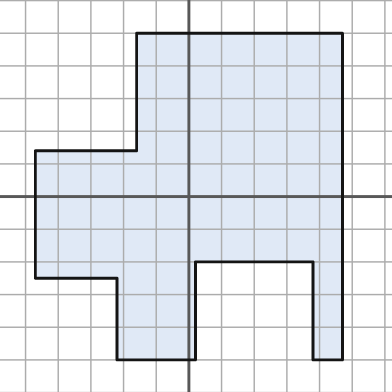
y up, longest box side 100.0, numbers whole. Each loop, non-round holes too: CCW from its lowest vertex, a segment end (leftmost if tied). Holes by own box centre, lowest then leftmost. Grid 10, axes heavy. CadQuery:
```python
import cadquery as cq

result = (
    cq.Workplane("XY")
    .moveTo(-22.0, -50.0)
    .lineTo(2.0, -50.0)
    .lineTo(2.0, -20.0)
    .lineTo(38.0, -20.0)
    .lineTo(38.0, -50.0)
    .lineTo(47.0, -50.0)
    .lineTo(47.0, 50.0)
    .lineTo(-16.0, 50.0)
    .lineTo(-16.0, 14.0)
    .lineTo(-47.0, 14.0)
    .lineTo(-47.0, -25.0)
    .lineTo(-22.0, -25.0)
    .close()
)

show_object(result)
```